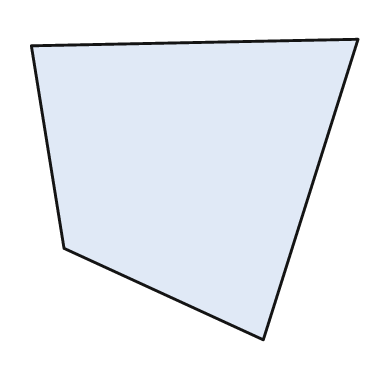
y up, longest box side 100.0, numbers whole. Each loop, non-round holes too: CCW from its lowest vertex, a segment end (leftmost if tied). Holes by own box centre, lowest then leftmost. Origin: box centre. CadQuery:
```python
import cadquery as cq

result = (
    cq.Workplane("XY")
    .moveTo(21.0, -46.0)
    .lineTo(50.0, 46.0)
    .lineTo(-50.0, 44.0)
    .lineTo(-40.0, -18.0)
    .close()
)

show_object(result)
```